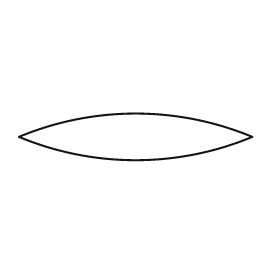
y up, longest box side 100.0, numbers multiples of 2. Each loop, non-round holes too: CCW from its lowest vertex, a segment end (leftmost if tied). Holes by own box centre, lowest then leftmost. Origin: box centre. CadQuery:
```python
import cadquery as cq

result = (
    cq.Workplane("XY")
    .moveTo(-50.0, 0.0)
    .threePointArc((0.0, -10.0), (50.0, 0.0))
    .threePointArc((0.0, 10.0), (-50.0, 0.0))
    .close()
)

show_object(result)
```